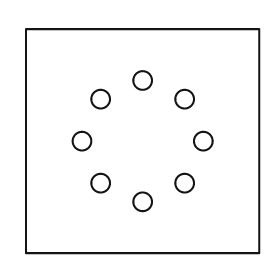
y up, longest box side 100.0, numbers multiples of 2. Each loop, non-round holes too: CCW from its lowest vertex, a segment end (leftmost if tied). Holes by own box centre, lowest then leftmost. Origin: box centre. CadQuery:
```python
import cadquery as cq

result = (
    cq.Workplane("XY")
    .moveTo(-50.0, -48.0)
    .lineTo(50.0, -48.0)
    .lineTo(50.0, 48.0)
    .lineTo(-50.0, 48.0)
    .close()
    .moveTo(0.0, -26.0)
    .circle(4.0)
    .moveTo(-18.0, -18.0)
    .circle(4.0)
    .moveTo(18.0, -18.0)
    .circle(4.0)
    .moveTo(-26.0, 0.0)
    .circle(4.0)
    .moveTo(26.0, 0.0)
    .circle(4.0)
    .moveTo(-18.0, 18.0)
    .circle(4.0)
    .moveTo(18.0, 18.0)
    .circle(4.0)
    .moveTo(0.0, 26.0)
    .circle(4.0)
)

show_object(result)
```